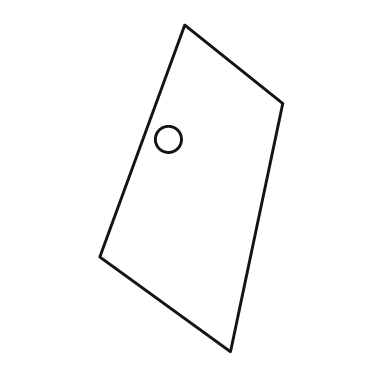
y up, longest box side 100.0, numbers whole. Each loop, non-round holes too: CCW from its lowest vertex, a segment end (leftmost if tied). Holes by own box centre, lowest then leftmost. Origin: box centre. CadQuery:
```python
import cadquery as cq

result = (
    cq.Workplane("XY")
    .moveTo(12.0, -50.0)
    .lineTo(28.0, 26.0)
    .lineTo(-2.0, 50.0)
    .lineTo(-28.0, -21.0)
    .close()
    .moveTo(-7.0, 15.0)
    .circle(4.0)
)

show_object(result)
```